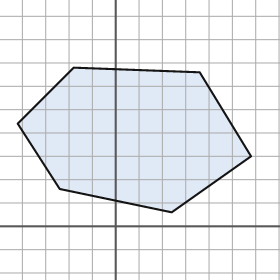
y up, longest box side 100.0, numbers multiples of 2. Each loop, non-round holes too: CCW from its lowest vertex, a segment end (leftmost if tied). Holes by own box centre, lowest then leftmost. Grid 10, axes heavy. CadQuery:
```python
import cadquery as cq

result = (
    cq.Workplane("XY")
    .moveTo(24.0, 6.0)
    .lineTo(58.0, 30.0)
    .lineTo(36.0, 66.0)
    .lineTo(-18.0, 68.0)
    .lineTo(-42.0, 44.0)
    .lineTo(-24.0, 16.0)
    .close()
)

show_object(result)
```